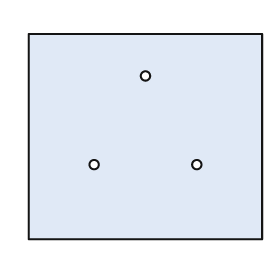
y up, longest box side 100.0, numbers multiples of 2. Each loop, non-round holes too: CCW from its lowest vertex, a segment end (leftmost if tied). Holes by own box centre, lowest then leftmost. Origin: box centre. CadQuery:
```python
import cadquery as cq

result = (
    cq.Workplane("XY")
    .moveTo(-50.0, -44.0)
    .lineTo(50.0, -44.0)
    .lineTo(50.0, 44.0)
    .lineTo(-50.0, 44.0)
    .close()
    .moveTo(-22.0, -12.0)
    .circle(2.0)
    .moveTo(22.0, -12.0)
    .circle(2.0)
    .moveTo(0.0, 26.0)
    .circle(2.0)
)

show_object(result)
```